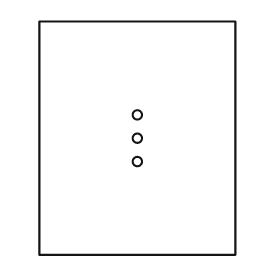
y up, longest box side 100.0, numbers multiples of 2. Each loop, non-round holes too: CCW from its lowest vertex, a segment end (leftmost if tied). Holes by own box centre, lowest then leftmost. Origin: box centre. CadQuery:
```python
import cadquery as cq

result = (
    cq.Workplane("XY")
    .moveTo(-42.0, -50.0)
    .lineTo(42.0, -50.0)
    .lineTo(42.0, 50.0)
    .lineTo(-42.0, 50.0)
    .close()
    .moveTo(0.0, -10.0)
    .circle(2.0)
    .moveTo(0.0, 0.0)
    .circle(2.0)
    .moveTo(0.0, 10.0)
    .circle(2.0)
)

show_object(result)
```